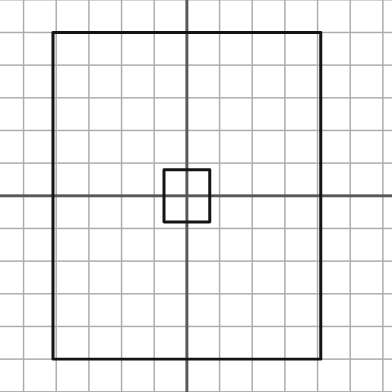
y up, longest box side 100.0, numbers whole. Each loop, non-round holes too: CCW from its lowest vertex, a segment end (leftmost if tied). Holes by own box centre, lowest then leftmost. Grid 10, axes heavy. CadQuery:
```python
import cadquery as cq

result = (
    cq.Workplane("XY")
    .moveTo(-41.0, -50.0)
    .lineTo(41.0, -50.0)
    .lineTo(41.0, 50.0)
    .lineTo(-41.0, 50.0)
    .close()
    .moveTo(-7.0, -8.0)
    .lineTo(7.0, -8.0)
    .lineTo(7.0, 8.0)
    .lineTo(-7.0, 8.0)
    .close()
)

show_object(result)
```